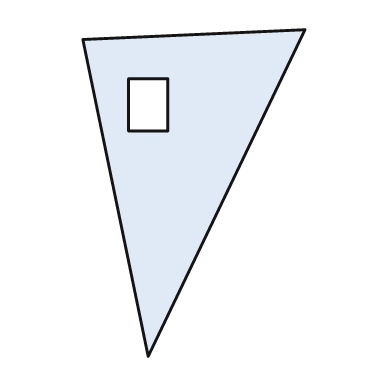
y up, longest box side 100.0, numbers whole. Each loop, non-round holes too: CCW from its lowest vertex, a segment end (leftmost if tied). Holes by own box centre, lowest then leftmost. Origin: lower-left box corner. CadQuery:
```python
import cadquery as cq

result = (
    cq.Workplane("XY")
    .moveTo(20.0, 0.0)
    .lineTo(68.0, 100.0)
    .lineTo(0.0, 97.0)
    .close()
    .moveTo(14.0, 69.0)
    .lineTo(26.0, 69.0)
    .lineTo(26.0, 85.0)
    .lineTo(14.0, 85.0)
    .close()
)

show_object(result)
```